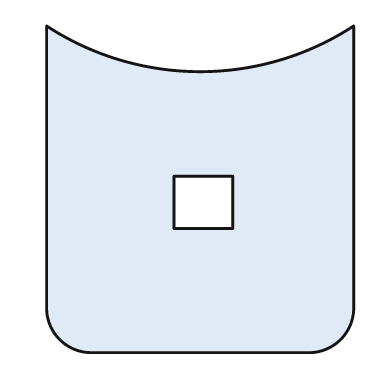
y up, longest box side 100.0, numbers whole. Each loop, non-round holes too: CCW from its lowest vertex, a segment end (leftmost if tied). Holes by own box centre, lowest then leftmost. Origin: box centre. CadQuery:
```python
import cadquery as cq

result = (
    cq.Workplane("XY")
    .moveTo(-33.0, -50.0)
    .lineTo(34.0, -50.0)
    .threePointArc((43.0, -46.0), (47.0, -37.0))
    .lineTo(47.0, 50.0)
    .threePointArc((0.0, 36.0), (-47.0, 50.0))
    .lineTo(-47.0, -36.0)
    .threePointArc((-43.0, -46.0), (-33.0, -50.0))
    .close()
    .moveTo(-8.0, -12.0)
    .lineTo(10.0, -12.0)
    .lineTo(10.0, 4.0)
    .lineTo(-8.0, 4.0)
    .close()
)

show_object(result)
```